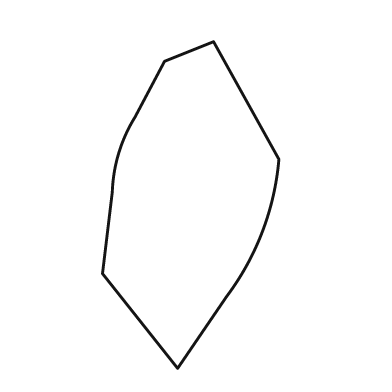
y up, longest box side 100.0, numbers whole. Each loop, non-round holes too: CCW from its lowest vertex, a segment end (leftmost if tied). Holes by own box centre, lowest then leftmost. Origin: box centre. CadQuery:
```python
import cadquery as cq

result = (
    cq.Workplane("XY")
    .moveTo(-4.0, -50.0)
    .lineTo(11.0, -28.0)
    .threePointArc((22.0, -8.0), (27.0, 14.0))
    .lineTo(7.0, 50.0)
    .lineTo(-8.0, 44.0)
    .lineTo(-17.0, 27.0)
    .threePointArc((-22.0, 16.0), (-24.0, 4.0))
    .lineTo(-27.0, -21.0)
    .close()
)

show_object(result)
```